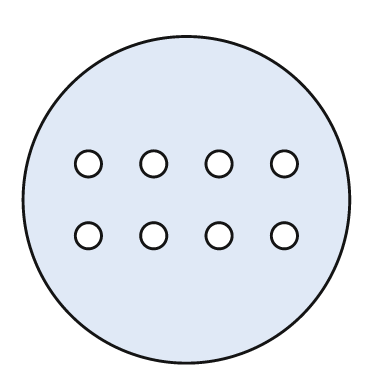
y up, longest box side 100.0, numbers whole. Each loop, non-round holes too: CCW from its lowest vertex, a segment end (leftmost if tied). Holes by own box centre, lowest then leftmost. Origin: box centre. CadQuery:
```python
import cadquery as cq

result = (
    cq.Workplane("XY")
    .moveTo(0.0, 0.0)
    .circle(50.0)
    .moveTo(-30.0, -11.0)
    .circle(4.0)
    .moveTo(-10.0, -11.0)
    .circle(4.0)
    .moveTo(10.0, -11.0)
    .circle(4.0)
    .moveTo(30.0, -11.0)
    .circle(4.0)
    .moveTo(-30.0, 11.0)
    .circle(4.0)
    .moveTo(-10.0, 11.0)
    .circle(4.0)
    .moveTo(10.0, 11.0)
    .circle(4.0)
    .moveTo(30.0, 11.0)
    .circle(4.0)
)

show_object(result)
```